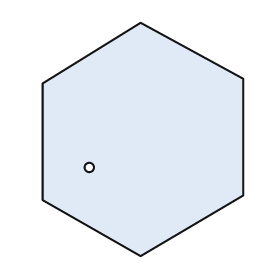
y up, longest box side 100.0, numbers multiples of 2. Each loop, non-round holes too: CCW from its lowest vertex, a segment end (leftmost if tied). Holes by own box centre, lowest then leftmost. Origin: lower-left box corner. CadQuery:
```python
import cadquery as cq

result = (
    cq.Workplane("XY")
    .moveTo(42.0, 0.0)
    .lineTo(86.0, 26.0)
    .lineTo(86.0, 76.0)
    .lineTo(42.0, 100.0)
    .lineTo(0.0, 74.0)
    .lineTo(0.0, 24.0)
    .close()
    .moveTo(20.0, 38.0)
    .circle(2.0)
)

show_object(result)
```